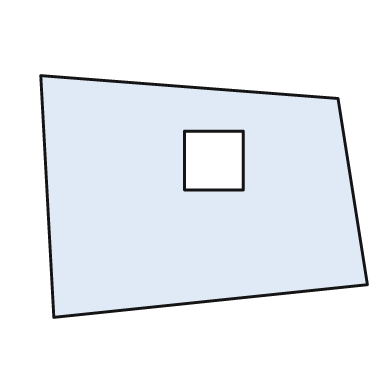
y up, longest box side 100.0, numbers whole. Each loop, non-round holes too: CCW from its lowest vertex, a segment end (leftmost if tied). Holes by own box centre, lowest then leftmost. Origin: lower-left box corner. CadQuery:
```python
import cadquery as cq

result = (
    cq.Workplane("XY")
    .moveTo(4.0, 0.0)
    .lineTo(100.0, 10.0)
    .lineTo(91.0, 67.0)
    .lineTo(0.0, 74.0)
    .close()
    .moveTo(44.0, 39.0)
    .lineTo(62.0, 39.0)
    .lineTo(62.0, 57.0)
    .lineTo(44.0, 57.0)
    .close()
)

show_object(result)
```